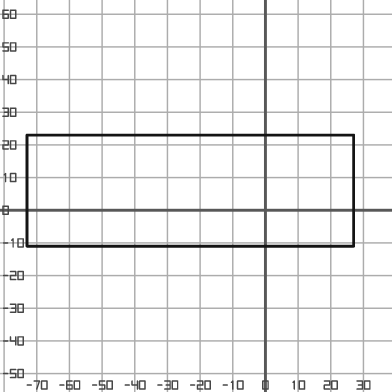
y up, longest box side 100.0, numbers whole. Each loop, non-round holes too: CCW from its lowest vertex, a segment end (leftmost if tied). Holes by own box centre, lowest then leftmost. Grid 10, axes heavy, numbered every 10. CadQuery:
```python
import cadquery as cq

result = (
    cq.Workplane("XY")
    .moveTo(-73.0, -11.0)
    .lineTo(27.0, -11.0)
    .lineTo(27.0, 23.0)
    .lineTo(-73.0, 23.0)
    .close()
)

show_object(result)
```